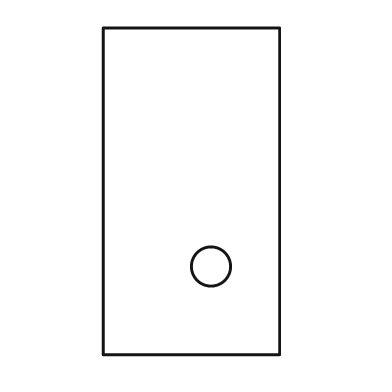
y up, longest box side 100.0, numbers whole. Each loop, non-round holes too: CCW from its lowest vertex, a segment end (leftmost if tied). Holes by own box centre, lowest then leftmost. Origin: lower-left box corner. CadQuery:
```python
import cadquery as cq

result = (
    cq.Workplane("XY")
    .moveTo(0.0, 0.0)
    .lineTo(54.0, 0.0)
    .lineTo(54.0, 100.0)
    .lineTo(0.0, 100.0)
    .close()
    .moveTo(33.0, 27.0)
    .circle(6.0)
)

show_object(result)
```